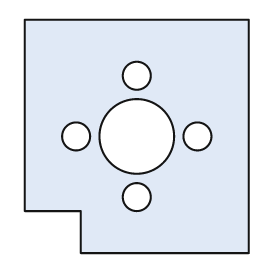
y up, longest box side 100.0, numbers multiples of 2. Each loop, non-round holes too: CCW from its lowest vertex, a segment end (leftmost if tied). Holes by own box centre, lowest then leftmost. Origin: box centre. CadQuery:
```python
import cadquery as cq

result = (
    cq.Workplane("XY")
    .moveTo(-24.0, -50.0)
    .lineTo(48.0, -50.0)
    .lineTo(48.0, 50.0)
    .lineTo(-48.0, 50.0)
    .lineTo(-48.0, -32.0)
    .lineTo(-24.0, -32.0)
    .close()
    .moveTo(0.0, -26.0)
    .circle(6.0)
    .moveTo(-26.0, 0.0)
    .circle(6.0)
    .moveTo(0.0, 0.0)
    .circle(16.0)
    .moveTo(26.0, 0.0)
    .circle(6.0)
    .moveTo(0.0, 26.0)
    .circle(6.0)
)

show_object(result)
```